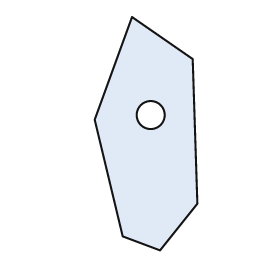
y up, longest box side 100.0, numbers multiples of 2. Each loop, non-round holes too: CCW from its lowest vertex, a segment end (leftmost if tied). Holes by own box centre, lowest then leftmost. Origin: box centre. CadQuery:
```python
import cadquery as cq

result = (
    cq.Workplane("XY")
    .moveTo(6.0, -50.0)
    .lineTo(22.0, -30.0)
    .lineTo(20.0, 32.0)
    .lineTo(-6.0, 50.0)
    .lineTo(-22.0, 6.0)
    .lineTo(-10.0, -44.0)
    .close()
    .moveTo(2.0, 8.0)
    .circle(6.0)
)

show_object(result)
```